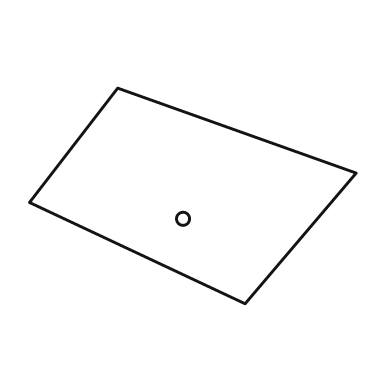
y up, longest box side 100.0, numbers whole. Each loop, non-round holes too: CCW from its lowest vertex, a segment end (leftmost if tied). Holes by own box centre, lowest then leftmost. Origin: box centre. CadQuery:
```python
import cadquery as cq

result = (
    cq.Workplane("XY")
    .moveTo(16.0, -33.0)
    .lineTo(50.0, 7.0)
    .lineTo(-23.0, 33.0)
    .lineTo(-50.0, -2.0)
    .close()
    .moveTo(-3.0, -7.0)
    .circle(2.0)
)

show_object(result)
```